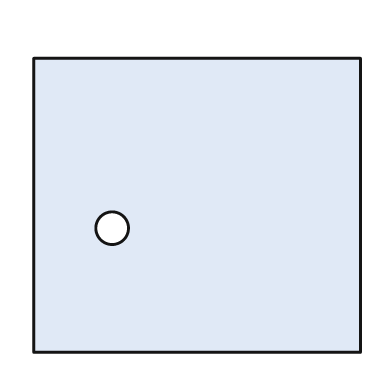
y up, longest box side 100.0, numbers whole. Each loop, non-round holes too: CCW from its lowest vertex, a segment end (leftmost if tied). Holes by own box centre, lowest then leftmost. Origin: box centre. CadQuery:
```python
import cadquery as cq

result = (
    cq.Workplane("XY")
    .moveTo(-50.0, -45.0)
    .lineTo(50.0, -45.0)
    .lineTo(50.0, 45.0)
    .lineTo(-50.0, 45.0)
    .close()
    .moveTo(-26.0, -7.0)
    .circle(5.0)
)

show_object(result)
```